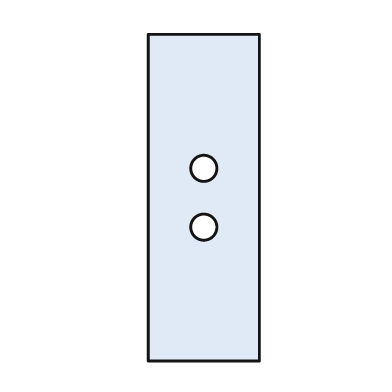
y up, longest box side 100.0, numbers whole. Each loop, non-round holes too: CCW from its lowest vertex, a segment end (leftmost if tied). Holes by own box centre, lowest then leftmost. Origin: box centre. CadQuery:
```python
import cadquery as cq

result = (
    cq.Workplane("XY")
    .moveTo(-17.0, -50.0)
    .lineTo(17.0, -50.0)
    .lineTo(17.0, 50.0)
    .lineTo(-17.0, 50.0)
    .close()
    .moveTo(0.0, -9.0)
    .circle(4.0)
    .moveTo(0.0, 9.0)
    .circle(4.0)
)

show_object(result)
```